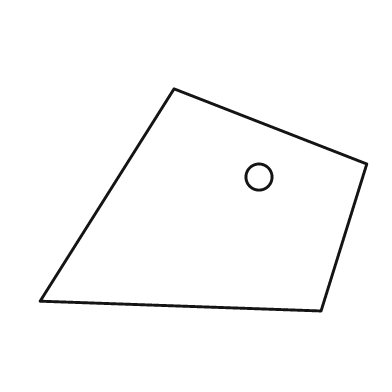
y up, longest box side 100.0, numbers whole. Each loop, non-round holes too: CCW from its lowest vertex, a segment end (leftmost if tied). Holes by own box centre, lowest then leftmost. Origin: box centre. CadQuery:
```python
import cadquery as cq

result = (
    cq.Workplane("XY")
    .moveTo(36.0, -34.0)
    .lineTo(50.0, 11.0)
    .lineTo(-9.0, 34.0)
    .lineTo(-50.0, -31.0)
    .close()
    .moveTo(17.0, 7.0)
    .circle(4.0)
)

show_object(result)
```